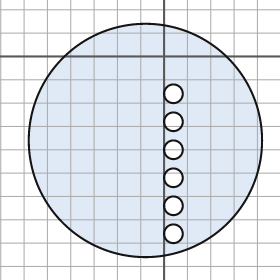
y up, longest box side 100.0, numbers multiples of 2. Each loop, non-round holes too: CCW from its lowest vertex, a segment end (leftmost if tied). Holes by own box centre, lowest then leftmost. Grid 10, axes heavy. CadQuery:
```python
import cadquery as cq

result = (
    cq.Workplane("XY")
    .moveTo(-8.0, -36.0)
    .circle(50.0)
    .moveTo(4.0, -76.0)
    .circle(4.0)
    .moveTo(4.0, -64.0)
    .circle(4.0)
    .moveTo(4.0, -52.0)
    .circle(4.0)
    .moveTo(4.0, -40.0)
    .circle(4.0)
    .moveTo(4.0, -28.0)
    .circle(4.0)
    .moveTo(4.0, -16.0)
    .circle(4.0)
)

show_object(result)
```